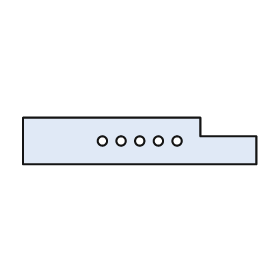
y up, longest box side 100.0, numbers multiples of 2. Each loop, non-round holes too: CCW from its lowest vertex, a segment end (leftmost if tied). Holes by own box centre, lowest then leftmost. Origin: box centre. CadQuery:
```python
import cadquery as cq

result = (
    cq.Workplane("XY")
    .moveTo(-50.0, -10.0)
    .lineTo(50.0, -10.0)
    .lineTo(50.0, 2.0)
    .lineTo(26.0, 2.0)
    .lineTo(26.0, 10.0)
    .lineTo(-50.0, 10.0)
    .close()
    .moveTo(-16.0, 0.0)
    .circle(2.0)
    .moveTo(-8.0, 0.0)
    .circle(2.0)
    .moveTo(0.0, 0.0)
    .circle(2.0)
    .moveTo(8.0, 0.0)
    .circle(2.0)
    .moveTo(16.0, 0.0)
    .circle(2.0)
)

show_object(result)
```